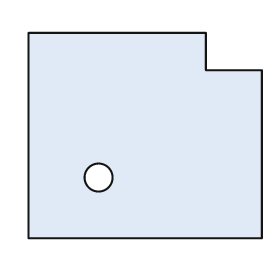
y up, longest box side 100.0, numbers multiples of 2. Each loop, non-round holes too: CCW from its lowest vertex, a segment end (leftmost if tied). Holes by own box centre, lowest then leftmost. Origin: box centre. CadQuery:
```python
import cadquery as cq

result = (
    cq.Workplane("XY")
    .moveTo(-50.0, -44.0)
    .lineTo(50.0, -44.0)
    .lineTo(50.0, 28.0)
    .lineTo(26.0, 28.0)
    .lineTo(26.0, 44.0)
    .lineTo(-50.0, 44.0)
    .close()
    .moveTo(-20.0, -18.0)
    .circle(6.0)
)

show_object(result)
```